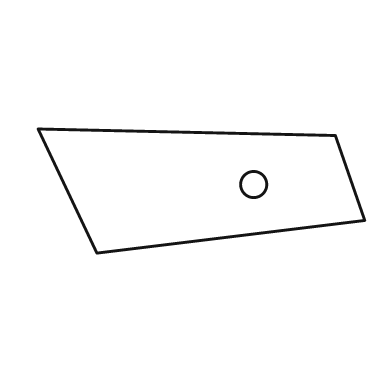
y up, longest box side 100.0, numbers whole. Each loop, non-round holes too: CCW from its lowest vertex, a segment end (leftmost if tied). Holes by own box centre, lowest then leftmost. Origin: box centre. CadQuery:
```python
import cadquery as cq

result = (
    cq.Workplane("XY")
    .moveTo(-32.0, -19.0)
    .lineTo(50.0, -9.0)
    .lineTo(41.0, 17.0)
    .lineTo(-50.0, 19.0)
    .close()
    .moveTo(16.0, 2.0)
    .circle(4.0)
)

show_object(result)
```